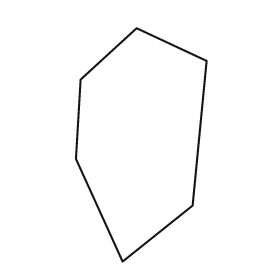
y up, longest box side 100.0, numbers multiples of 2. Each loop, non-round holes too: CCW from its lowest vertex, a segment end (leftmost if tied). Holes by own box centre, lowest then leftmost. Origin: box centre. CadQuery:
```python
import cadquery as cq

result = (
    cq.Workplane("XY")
    .moveTo(-8.0, -50.0)
    .lineTo(22.0, -26.0)
    .lineTo(28.0, 36.0)
    .lineTo(-2.0, 50.0)
    .lineTo(-26.0, 28.0)
    .lineTo(-28.0, -6.0)
    .close()
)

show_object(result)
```